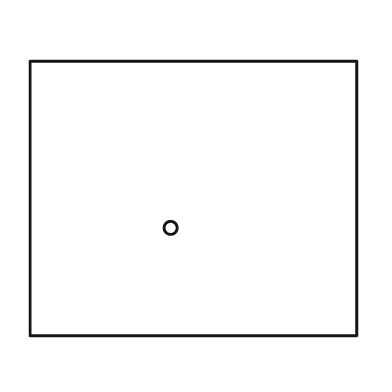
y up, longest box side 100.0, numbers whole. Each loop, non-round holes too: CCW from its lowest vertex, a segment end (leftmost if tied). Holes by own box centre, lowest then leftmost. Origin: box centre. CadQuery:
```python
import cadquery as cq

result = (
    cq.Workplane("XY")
    .moveTo(-50.0, -42.0)
    .lineTo(50.0, -42.0)
    .lineTo(50.0, 42.0)
    .lineTo(-50.0, 42.0)
    .close()
    .moveTo(-7.0, -9.0)
    .circle(2.0)
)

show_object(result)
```